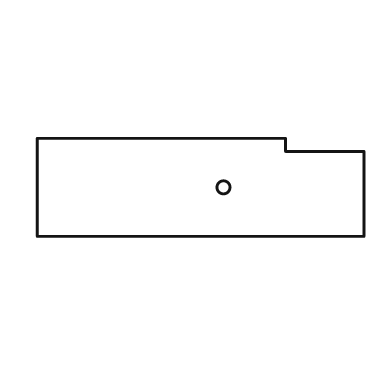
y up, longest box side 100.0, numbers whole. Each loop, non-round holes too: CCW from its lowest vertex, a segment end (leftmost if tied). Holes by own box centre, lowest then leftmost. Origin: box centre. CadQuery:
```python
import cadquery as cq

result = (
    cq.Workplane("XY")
    .moveTo(-50.0, -15.0)
    .lineTo(50.0, -15.0)
    .lineTo(50.0, 11.0)
    .lineTo(26.0, 11.0)
    .lineTo(26.0, 15.0)
    .lineTo(-50.0, 15.0)
    .close()
    .moveTo(7.0, 0.0)
    .circle(2.0)
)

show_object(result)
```